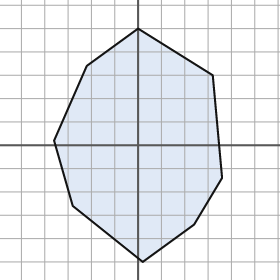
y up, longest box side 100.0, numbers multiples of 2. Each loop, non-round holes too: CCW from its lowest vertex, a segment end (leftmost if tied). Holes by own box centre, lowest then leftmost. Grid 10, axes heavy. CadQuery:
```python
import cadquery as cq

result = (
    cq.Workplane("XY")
    .moveTo(2.0, -50.0)
    .lineTo(24.0, -34.0)
    .lineTo(36.0, -14.0)
    .lineTo(32.0, 30.0)
    .lineTo(0.0, 50.0)
    .lineTo(-22.0, 34.0)
    .lineTo(-36.0, 2.0)
    .lineTo(-28.0, -26.0)
    .close()
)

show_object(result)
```